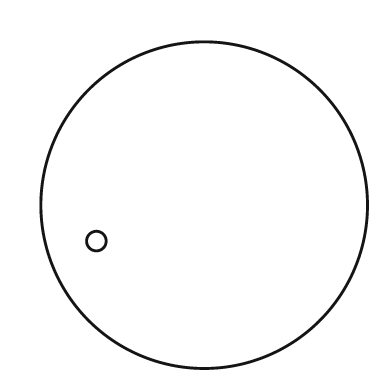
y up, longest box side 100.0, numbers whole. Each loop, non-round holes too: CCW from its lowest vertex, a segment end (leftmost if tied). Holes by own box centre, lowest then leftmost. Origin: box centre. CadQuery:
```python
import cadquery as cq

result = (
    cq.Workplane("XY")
    .moveTo(0.0, 0.0)
    .circle(50.0)
    .moveTo(-33.0, -11.0)
    .circle(3.0)
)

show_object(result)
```